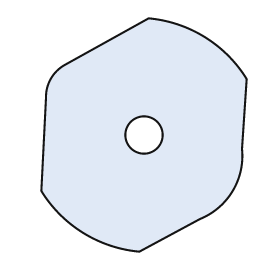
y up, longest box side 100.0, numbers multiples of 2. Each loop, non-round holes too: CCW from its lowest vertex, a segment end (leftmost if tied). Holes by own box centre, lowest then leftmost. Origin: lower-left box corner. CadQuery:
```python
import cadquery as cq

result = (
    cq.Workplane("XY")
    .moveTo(42.0, 0.0)
    .lineTo(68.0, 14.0)
    .threePointArc((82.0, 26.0), (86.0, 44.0))
    .lineTo(88.0, 74.0)
    .threePointArc((70.0, 92.0), (46.0, 100.0))
    .lineTo(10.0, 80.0)
    .threePointArc((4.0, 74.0), (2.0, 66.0))
    .lineTo(0.0, 26.0)
    .threePointArc((18.0, 8.0), (42.0, 0.0))
    .close()
    .moveTo(44.0, 50.0)
    .circle(8.0)
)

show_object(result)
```